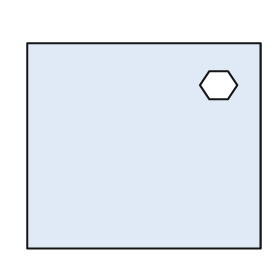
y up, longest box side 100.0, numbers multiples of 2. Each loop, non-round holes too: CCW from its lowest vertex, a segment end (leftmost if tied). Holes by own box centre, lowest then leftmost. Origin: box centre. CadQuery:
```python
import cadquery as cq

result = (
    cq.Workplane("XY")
    .moveTo(-50.0, -44.0)
    .lineTo(50.0, -44.0)
    .lineTo(50.0, 44.0)
    .lineTo(-50.0, 44.0)
    .close()
    .moveTo(28.0, 20.0)
    .lineTo(36.0, 20.0)
    .lineTo(40.0, 26.0)
    .lineTo(36.0, 32.0)
    .lineTo(28.0, 32.0)
    .lineTo(24.0, 26.0)
    .close()
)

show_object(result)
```